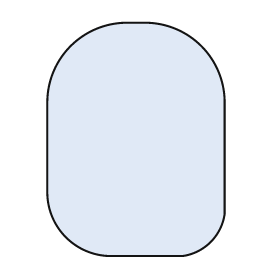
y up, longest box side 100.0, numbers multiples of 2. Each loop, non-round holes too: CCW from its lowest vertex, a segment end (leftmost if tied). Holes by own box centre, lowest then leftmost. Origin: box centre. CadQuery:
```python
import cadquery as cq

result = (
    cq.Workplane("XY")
    .moveTo(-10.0, -50.0)
    .lineTo(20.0, -50.0)
    .threePointArc((32.0, -44.0), (38.0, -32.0))
    .lineTo(38.0, 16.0)
    .threePointArc((28.0, 40.0), (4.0, 50.0))
    .lineTo(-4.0, 50.0)
    .threePointArc((-28.0, 40.0), (-38.0, 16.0))
    .lineTo(-38.0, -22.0)
    .threePointArc((-30.0, -42.0), (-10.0, -50.0))
    .close()
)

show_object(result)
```